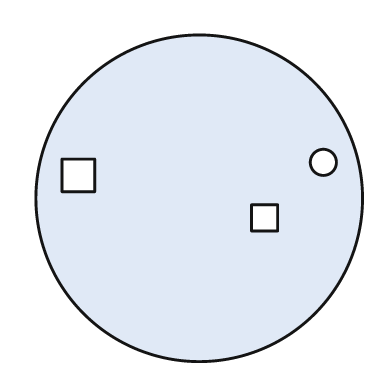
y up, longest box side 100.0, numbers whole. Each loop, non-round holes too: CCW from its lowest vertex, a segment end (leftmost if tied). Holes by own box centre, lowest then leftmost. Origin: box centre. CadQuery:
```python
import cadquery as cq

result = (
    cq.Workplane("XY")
    .moveTo(0.0, 0.0)
    .circle(50.0)
    .moveTo(16.0, -10.0)
    .lineTo(24.0, -10.0)
    .lineTo(24.0, -2.0)
    .lineTo(16.0, -2.0)
    .close()
    .moveTo(-42.0, 2.0)
    .lineTo(-32.0, 2.0)
    .lineTo(-32.0, 12.0)
    .lineTo(-42.0, 12.0)
    .close()
    .moveTo(38.0, 11.0)
    .circle(4.0)
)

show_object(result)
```